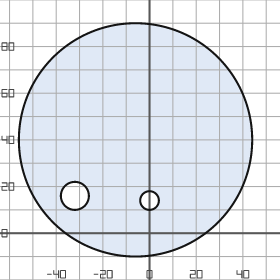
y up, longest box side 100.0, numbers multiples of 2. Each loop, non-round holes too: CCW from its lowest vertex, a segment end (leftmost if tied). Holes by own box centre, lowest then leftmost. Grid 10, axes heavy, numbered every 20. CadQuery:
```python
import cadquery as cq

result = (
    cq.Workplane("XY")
    .moveTo(-6.0, 40.0)
    .circle(50.0)
    .moveTo(0.0, 14.0)
    .circle(4.0)
    .moveTo(-32.0, 16.0)
    .circle(6.0)
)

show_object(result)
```